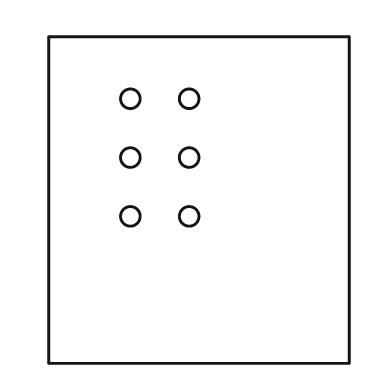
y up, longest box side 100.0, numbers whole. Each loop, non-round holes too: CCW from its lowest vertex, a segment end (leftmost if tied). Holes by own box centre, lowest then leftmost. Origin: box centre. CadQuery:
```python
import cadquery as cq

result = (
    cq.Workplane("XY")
    .moveTo(-46.0, -50.0)
    .lineTo(46.0, -50.0)
    .lineTo(46.0, 50.0)
    .lineTo(-46.0, 50.0)
    .close()
    .moveTo(-21.0, -5.0)
    .circle(3.0)
    .moveTo(-3.0, -5.0)
    .circle(3.0)
    .moveTo(-21.0, 13.0)
    .circle(3.0)
    .moveTo(-3.0, 13.0)
    .circle(3.0)
    .moveTo(-21.0, 31.0)
    .circle(3.0)
    .moveTo(-3.0, 31.0)
    .circle(3.0)
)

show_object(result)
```